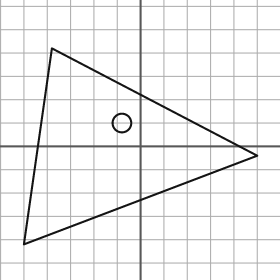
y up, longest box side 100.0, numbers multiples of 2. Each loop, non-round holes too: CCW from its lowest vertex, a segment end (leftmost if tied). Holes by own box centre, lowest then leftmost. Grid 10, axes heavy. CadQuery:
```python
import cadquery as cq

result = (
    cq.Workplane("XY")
    .moveTo(-50.0, -42.0)
    .lineTo(50.0, -4.0)
    .lineTo(-38.0, 42.0)
    .close()
    .moveTo(-8.0, 10.0)
    .circle(4.0)
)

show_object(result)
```